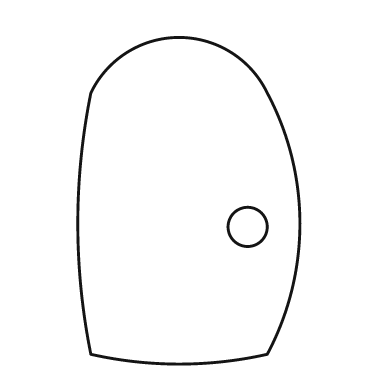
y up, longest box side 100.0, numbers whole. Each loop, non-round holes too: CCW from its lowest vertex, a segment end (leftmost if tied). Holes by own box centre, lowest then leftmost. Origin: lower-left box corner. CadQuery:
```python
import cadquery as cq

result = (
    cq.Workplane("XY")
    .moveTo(4.0, 3.0)
    .threePointArc((31.0, 0.0), (58.0, 3.0))
    .threePointArc((68.0, 43.0), (58.0, 83.0))
    .threePointArc((31.0, 100.0), (4.0, 83.0))
    .threePointArc((0.0, 43.0), (4.0, 3.0))
    .close()
    .moveTo(52.0, 42.0)
    .circle(6.0)
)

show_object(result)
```